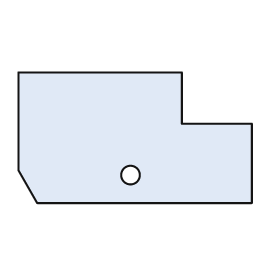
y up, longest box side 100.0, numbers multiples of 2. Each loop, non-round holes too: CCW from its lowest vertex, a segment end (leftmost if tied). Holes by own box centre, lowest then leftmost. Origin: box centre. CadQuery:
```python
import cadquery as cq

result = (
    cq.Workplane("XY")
    .moveTo(-42.0, -28.0)
    .lineTo(50.0, -28.0)
    .lineTo(50.0, 6.0)
    .lineTo(20.0, 6.0)
    .lineTo(20.0, 28.0)
    .lineTo(-50.0, 28.0)
    .lineTo(-50.0, -14.0)
    .close()
    .moveTo(-2.0, -16.0)
    .circle(4.0)
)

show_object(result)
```